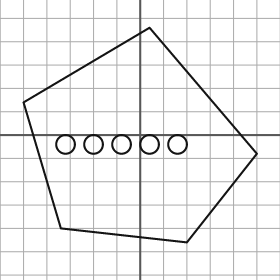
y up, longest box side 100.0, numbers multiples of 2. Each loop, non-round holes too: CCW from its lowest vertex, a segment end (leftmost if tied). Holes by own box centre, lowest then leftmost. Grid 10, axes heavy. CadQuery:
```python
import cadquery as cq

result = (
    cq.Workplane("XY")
    .moveTo(20.0, -46.0)
    .lineTo(50.0, -8.0)
    .lineTo(4.0, 46.0)
    .lineTo(-50.0, 14.0)
    .lineTo(-34.0, -40.0)
    .close()
    .moveTo(-32.0, -4.0)
    .circle(4.0)
    .moveTo(-20.0, -4.0)
    .circle(4.0)
    .moveTo(-8.0, -4.0)
    .circle(4.0)
    .moveTo(4.0, -4.0)
    .circle(4.0)
    .moveTo(16.0, -4.0)
    .circle(4.0)
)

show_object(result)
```